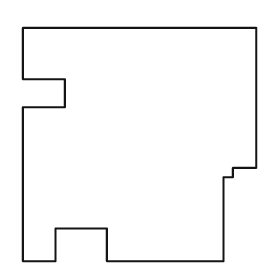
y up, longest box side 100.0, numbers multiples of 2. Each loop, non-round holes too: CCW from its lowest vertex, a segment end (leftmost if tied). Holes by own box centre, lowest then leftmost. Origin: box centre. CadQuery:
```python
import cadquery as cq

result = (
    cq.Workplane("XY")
    .moveTo(-50.0, -50.0)
    .lineTo(-36.0, -50.0)
    .lineTo(-36.0, -36.0)
    .lineTo(-14.0, -36.0)
    .lineTo(-14.0, -50.0)
    .lineTo(36.0, -50.0)
    .lineTo(36.0, -14.0)
    .lineTo(40.0, -14.0)
    .lineTo(40.0, -10.0)
    .lineTo(50.0, -10.0)
    .lineTo(50.0, 50.0)
    .lineTo(-50.0, 50.0)
    .lineTo(-50.0, 28.0)
    .lineTo(-32.0, 28.0)
    .lineTo(-32.0, 16.0)
    .lineTo(-50.0, 16.0)
    .close()
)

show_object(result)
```